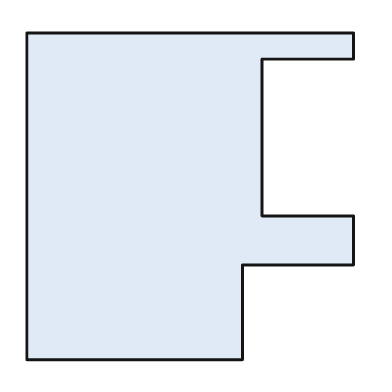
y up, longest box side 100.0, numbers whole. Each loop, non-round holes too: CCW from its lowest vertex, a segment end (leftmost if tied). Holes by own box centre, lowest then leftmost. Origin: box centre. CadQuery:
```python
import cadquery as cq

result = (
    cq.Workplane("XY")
    .moveTo(-50.0, -50.0)
    .lineTo(16.0, -50.0)
    .lineTo(16.0, -21.0)
    .lineTo(50.0, -21.0)
    .lineTo(50.0, -6.0)
    .lineTo(22.0, -6.0)
    .lineTo(22.0, 42.0)
    .lineTo(50.0, 42.0)
    .lineTo(50.0, 50.0)
    .lineTo(-50.0, 50.0)
    .close()
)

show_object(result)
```